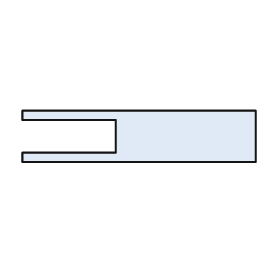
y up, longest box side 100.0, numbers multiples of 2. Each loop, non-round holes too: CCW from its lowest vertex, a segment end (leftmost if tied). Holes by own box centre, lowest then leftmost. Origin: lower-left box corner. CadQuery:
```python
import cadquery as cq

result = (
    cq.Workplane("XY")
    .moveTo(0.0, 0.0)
    .lineTo(100.0, 0.0)
    .lineTo(100.0, 22.0)
    .lineTo(0.0, 22.0)
    .lineTo(0.0, 18.0)
    .lineTo(40.0, 18.0)
    .lineTo(40.0, 4.0)
    .lineTo(0.0, 4.0)
    .close()
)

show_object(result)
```